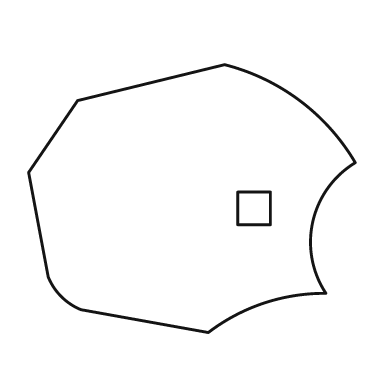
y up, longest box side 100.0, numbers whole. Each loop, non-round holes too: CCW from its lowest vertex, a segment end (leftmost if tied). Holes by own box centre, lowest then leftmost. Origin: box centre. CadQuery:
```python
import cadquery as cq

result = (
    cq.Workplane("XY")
    .moveTo(5.0, -41.0)
    .threePointArc((22.0, -32.0), (41.0, -29.0))
    .threePointArc((37.0, -7.0), (50.0, 11.0))
    .threePointArc((33.0, 30.0), (10.0, 41.0))
    .lineTo(-35.0, 30.0)
    .lineTo(-50.0, 8.0)
    .lineTo(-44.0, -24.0)
    .threePointArc((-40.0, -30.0), (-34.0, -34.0))
    .close()
    .moveTo(14.0, -8.0)
    .lineTo(24.0, -8.0)
    .lineTo(24.0, 2.0)
    .lineTo(14.0, 2.0)
    .close()
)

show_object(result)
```